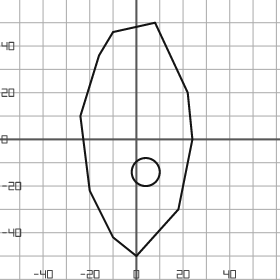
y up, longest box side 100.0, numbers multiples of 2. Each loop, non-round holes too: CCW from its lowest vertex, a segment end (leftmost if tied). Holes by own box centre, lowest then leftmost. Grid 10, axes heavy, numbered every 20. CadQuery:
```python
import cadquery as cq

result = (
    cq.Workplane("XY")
    .moveTo(0.0, -50.0)
    .lineTo(18.0, -30.0)
    .lineTo(24.0, 0.0)
    .lineTo(22.0, 20.0)
    .lineTo(8.0, 50.0)
    .lineTo(-10.0, 46.0)
    .lineTo(-16.0, 36.0)
    .lineTo(-24.0, 10.0)
    .lineTo(-20.0, -22.0)
    .lineTo(-10.0, -42.0)
    .close()
    .moveTo(4.0, -14.0)
    .circle(6.0)
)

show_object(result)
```